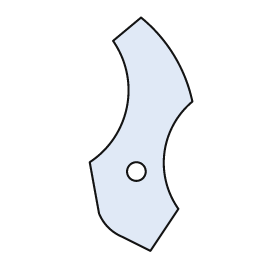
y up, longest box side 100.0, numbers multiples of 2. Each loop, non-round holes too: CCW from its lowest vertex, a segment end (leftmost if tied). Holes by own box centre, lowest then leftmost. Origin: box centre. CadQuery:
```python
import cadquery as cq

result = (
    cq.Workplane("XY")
    .moveTo(4.0, -50.0)
    .lineTo(16.0, -32.0)
    .threePointArc((10.0, -8.0), (22.0, 14.0))
    .threePointArc((14.0, 34.0), (0.0, 50.0))
    .lineTo(-12.0, 40.0)
    .threePointArc((-6.0, 12.0), (-22.0, -12.0))
    .lineTo(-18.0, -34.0)
    .threePointArc((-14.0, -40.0), (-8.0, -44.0))
    .close()
    .moveTo(-2.0, -16.0)
    .circle(4.0)
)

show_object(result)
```